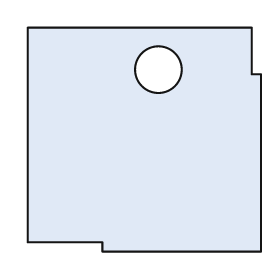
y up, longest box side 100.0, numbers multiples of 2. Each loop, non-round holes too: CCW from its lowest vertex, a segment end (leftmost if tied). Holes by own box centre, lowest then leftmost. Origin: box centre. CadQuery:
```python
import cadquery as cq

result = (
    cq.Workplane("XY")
    .moveTo(-18.0, -48.0)
    .lineTo(50.0, -48.0)
    .lineTo(50.0, 28.0)
    .lineTo(46.0, 28.0)
    .lineTo(46.0, 48.0)
    .lineTo(-50.0, 48.0)
    .lineTo(-50.0, -44.0)
    .lineTo(-18.0, -44.0)
    .close()
    .moveTo(6.0, 30.0)
    .circle(10.0)
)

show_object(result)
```